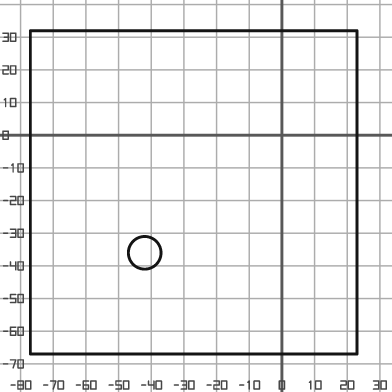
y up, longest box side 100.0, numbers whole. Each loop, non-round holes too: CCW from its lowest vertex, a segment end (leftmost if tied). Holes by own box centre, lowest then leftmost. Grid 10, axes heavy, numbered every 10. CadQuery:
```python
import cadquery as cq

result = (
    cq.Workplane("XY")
    .moveTo(-77.0, -67.0)
    .lineTo(23.0, -67.0)
    .lineTo(23.0, 32.0)
    .lineTo(-77.0, 32.0)
    .close()
    .moveTo(-42.0, -36.0)
    .circle(5.0)
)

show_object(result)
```